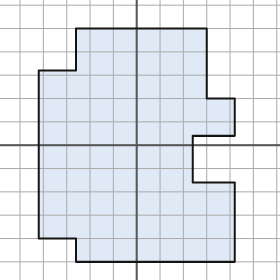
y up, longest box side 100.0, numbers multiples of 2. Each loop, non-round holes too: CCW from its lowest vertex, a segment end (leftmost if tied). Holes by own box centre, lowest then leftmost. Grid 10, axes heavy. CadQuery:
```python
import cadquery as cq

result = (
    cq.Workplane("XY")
    .moveTo(-26.0, -50.0)
    .lineTo(42.0, -50.0)
    .lineTo(42.0, -16.0)
    .lineTo(24.0, -16.0)
    .lineTo(24.0, 4.0)
    .lineTo(42.0, 4.0)
    .lineTo(42.0, 20.0)
    .lineTo(30.0, 20.0)
    .lineTo(30.0, 50.0)
    .lineTo(-26.0, 50.0)
    .lineTo(-26.0, 32.0)
    .lineTo(-42.0, 32.0)
    .lineTo(-42.0, -40.0)
    .lineTo(-26.0, -40.0)
    .close()
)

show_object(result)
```